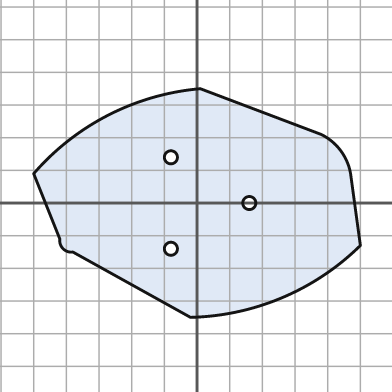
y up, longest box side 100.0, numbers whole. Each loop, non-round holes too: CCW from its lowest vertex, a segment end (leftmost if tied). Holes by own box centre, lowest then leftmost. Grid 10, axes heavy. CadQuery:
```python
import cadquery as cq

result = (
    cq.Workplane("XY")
    .moveTo(-2.0, -35.0)
    .threePointArc((26.0, -29.0), (50.0, -13.0))
    .lineTo(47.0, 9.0)
    .threePointArc((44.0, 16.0), (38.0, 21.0))
    .lineTo(1.0, 35.0)
    .threePointArc((-27.0, 27.0), (-50.0, 9.0))
    .lineTo(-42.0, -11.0)
    .threePointArc((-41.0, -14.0), (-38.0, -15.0))
    .close()
    .moveTo(-8.0, -14.0)
    .circle(2.0)
    .moveTo(16.0, 0.0)
    .circle(2.0)
    .moveTo(-8.0, 14.0)
    .circle(2.0)
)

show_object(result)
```